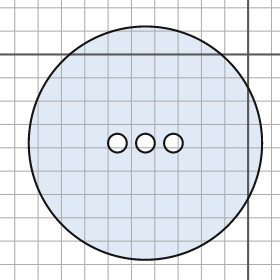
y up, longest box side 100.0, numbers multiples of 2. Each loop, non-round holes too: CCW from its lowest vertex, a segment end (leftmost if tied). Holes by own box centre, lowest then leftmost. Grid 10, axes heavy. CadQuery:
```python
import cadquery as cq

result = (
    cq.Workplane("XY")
    .moveTo(-44.0, -38.0)
    .circle(50.0)
    .moveTo(-56.0, -38.0)
    .circle(4.0)
    .moveTo(-44.0, -38.0)
    .circle(4.0)
    .moveTo(-32.0, -38.0)
    .circle(4.0)
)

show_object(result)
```